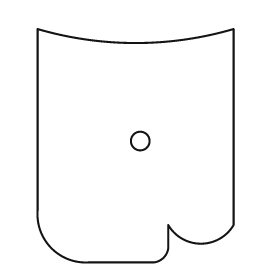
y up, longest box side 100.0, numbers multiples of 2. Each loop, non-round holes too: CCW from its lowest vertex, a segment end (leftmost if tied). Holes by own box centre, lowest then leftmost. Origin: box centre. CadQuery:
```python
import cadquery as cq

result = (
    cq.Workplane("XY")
    .moveTo(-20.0, -50.0)
    .lineTo(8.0, -50.0)
    .threePointArc((12.0, -48.0), (14.0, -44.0))
    .lineTo(14.0, -34.0)
    .threePointArc((28.0, -42.0), (42.0, -34.0))
    .lineTo(42.0, 50.0)
    .threePointArc((0.0, 44.0), (-42.0, 50.0))
    .lineTo(-42.0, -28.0)
    .threePointArc((-36.0, -44.0), (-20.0, -50.0))
    .close()
    .moveTo(2.0, 2.0)
    .circle(4.0)
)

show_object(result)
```